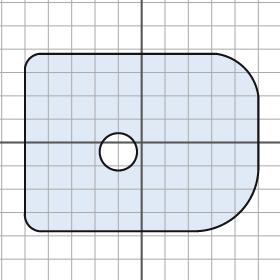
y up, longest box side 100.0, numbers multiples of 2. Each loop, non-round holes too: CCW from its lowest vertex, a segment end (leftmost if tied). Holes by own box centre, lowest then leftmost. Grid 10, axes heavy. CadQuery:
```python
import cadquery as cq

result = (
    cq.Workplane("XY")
    .moveTo(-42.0, -38.0)
    .lineTo(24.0, -38.0)
    .threePointArc((42.0, -30.0), (50.0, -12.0))
    .lineTo(50.0, 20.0)
    .threePointArc((44.0, 32.0), (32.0, 38.0))
    .lineTo(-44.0, 38.0)
    .threePointArc((-48.0, 36.0), (-50.0, 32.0))
    .lineTo(-50.0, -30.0)
    .threePointArc((-48.0, -36.0), (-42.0, -38.0))
    .close()
    .moveTo(-10.0, -4.0)
    .circle(8.0)
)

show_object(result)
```